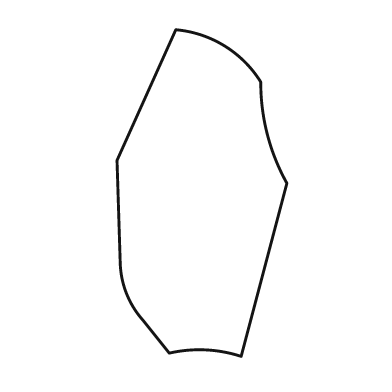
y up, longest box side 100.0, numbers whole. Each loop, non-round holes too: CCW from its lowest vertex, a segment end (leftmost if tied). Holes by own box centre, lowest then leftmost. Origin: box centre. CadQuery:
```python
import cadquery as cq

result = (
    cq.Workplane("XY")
    .moveTo(12.0, -50.0)
    .lineTo(26.0, 3.0)
    .threePointArc((20.0, 18.0), (18.0, 34.0))
    .threePointArc((7.0, 45.0), (-8.0, 50.0))
    .lineTo(-26.0, 10.0)
    .lineTo(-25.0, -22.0)
    .threePointArc((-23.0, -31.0), (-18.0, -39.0))
    .lineTo(-10.0, -49.0)
    .threePointArc((1.0, -48.0), (12.0, -50.0))
    .close()
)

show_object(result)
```